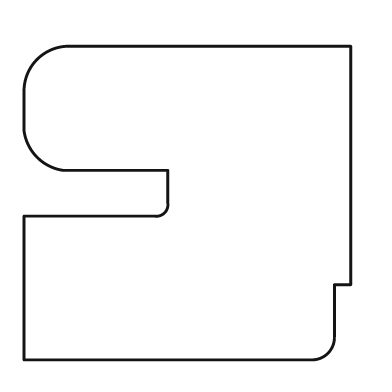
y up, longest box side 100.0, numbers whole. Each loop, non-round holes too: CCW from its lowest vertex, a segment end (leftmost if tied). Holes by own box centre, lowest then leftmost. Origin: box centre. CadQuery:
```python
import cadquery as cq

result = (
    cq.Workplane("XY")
    .moveTo(-50.0, -48.0)
    .lineTo(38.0, -48.0)
    .threePointArc((43.0, -46.0), (45.0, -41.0))
    .lineTo(45.0, -25.0)
    .lineTo(50.0, -25.0)
    .lineTo(50.0, 48.0)
    .lineTo(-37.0, 48.0)
    .threePointArc((-46.0, 44.0), (-50.0, 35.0))
    .lineTo(-50.0, 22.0)
    .threePointArc((-46.0, 14.0), (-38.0, 10.0))
    .lineTo(-6.0, 10.0)
    .lineTo(-6.0, 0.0)
    .threePointArc((-7.0, -3.0), (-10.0, -4.0))
    .lineTo(-50.0, -4.0)
    .close()
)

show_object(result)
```